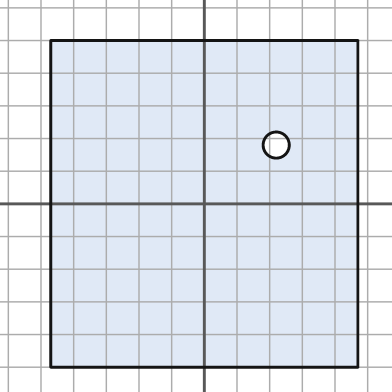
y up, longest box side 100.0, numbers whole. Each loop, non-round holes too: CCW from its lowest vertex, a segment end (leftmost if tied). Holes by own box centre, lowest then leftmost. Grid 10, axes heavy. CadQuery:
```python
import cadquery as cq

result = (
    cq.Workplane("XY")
    .moveTo(-47.0, -50.0)
    .lineTo(47.0, -50.0)
    .lineTo(47.0, 50.0)
    .lineTo(-47.0, 50.0)
    .close()
    .moveTo(22.0, 18.0)
    .circle(4.0)
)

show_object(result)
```